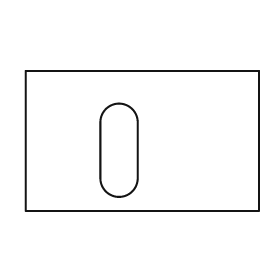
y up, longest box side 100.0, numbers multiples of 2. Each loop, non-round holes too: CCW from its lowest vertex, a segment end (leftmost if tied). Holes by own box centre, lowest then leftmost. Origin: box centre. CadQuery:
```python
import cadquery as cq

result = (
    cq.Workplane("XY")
    .moveTo(-50.0, -30.0)
    .lineTo(50.0, -30.0)
    .lineTo(50.0, 30.0)
    .lineTo(-50.0, 30.0)
    .close()
    .moveTo(-18.0, -16.0)
    .threePointArc((-10.0, -24.0), (-2.0, -16.0))
    .lineTo(-2.0, 8.0)
    .threePointArc((-10.0, 16.0), (-18.0, 8.0))
    .close()
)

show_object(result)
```